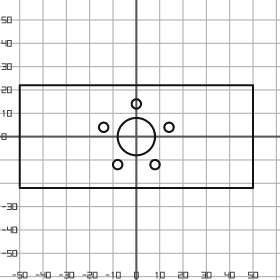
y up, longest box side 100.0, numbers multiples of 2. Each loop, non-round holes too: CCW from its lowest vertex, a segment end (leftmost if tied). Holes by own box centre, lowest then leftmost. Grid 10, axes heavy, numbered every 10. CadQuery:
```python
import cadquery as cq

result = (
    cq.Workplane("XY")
    .moveTo(-50.0, -22.0)
    .lineTo(50.0, -22.0)
    .lineTo(50.0, 22.0)
    .lineTo(-50.0, 22.0)
    .close()
    .moveTo(-8.0, -12.0)
    .circle(2.0)
    .moveTo(8.0, -12.0)
    .circle(2.0)
    .moveTo(0.0, 0.0)
    .circle(8.0)
    .moveTo(-14.0, 4.0)
    .circle(2.0)
    .moveTo(14.0, 4.0)
    .circle(2.0)
    .moveTo(0.0, 14.0)
    .circle(2.0)
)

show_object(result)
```